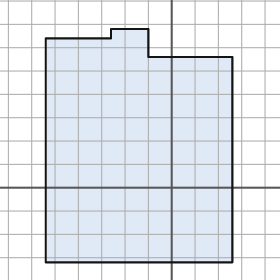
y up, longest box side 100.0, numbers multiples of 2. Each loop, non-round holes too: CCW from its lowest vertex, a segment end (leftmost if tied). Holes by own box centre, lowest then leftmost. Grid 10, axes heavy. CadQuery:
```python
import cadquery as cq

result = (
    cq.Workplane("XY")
    .moveTo(-54.0, -32.0)
    .lineTo(26.0, -32.0)
    .lineTo(26.0, 56.0)
    .lineTo(-10.0, 56.0)
    .lineTo(-10.0, 68.0)
    .lineTo(-26.0, 68.0)
    .lineTo(-26.0, 64.0)
    .lineTo(-54.0, 64.0)
    .close()
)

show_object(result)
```